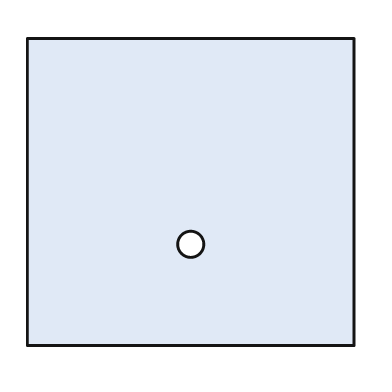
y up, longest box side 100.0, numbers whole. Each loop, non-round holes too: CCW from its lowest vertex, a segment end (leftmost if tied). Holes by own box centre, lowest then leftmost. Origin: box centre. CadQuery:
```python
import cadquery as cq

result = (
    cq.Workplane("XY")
    .moveTo(-50.0, -47.0)
    .lineTo(50.0, -47.0)
    .lineTo(50.0, 47.0)
    .lineTo(-50.0, 47.0)
    .close()
    .moveTo(0.0, -16.0)
    .circle(4.0)
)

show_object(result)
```